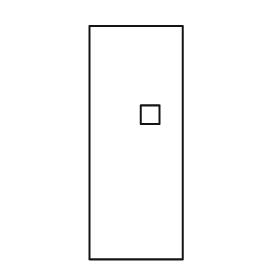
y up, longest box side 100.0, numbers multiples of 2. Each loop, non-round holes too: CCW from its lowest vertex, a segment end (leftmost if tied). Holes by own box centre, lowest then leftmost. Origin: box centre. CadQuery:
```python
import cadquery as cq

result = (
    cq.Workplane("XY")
    .moveTo(-20.0, -50.0)
    .lineTo(20.0, -50.0)
    .lineTo(20.0, 50.0)
    .lineTo(-20.0, 50.0)
    .close()
    .moveTo(2.0, 8.0)
    .lineTo(10.0, 8.0)
    .lineTo(10.0, 16.0)
    .lineTo(2.0, 16.0)
    .close()
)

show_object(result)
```